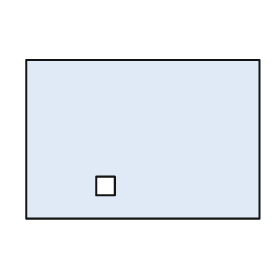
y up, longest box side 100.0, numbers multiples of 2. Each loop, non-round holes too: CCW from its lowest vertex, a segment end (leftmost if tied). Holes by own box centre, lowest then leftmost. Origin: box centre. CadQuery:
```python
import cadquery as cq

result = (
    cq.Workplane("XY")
    .moveTo(-50.0, -34.0)
    .lineTo(50.0, -34.0)
    .lineTo(50.0, 34.0)
    .lineTo(-50.0, 34.0)
    .close()
    .moveTo(-20.0, -24.0)
    .lineTo(-12.0, -24.0)
    .lineTo(-12.0, -16.0)
    .lineTo(-20.0, -16.0)
    .close()
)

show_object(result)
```